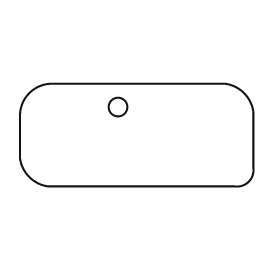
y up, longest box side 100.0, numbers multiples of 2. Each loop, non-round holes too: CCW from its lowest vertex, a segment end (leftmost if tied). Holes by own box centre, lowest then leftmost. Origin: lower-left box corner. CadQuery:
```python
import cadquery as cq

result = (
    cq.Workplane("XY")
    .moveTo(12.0, 0.0)
    .lineTo(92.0, 0.0)
    .threePointArc((98.0, 2.0), (100.0, 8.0))
    .lineTo(100.0, 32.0)
    .threePointArc((96.0, 40.0), (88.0, 44.0))
    .lineTo(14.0, 44.0)
    .threePointArc((4.0, 40.0), (0.0, 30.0))
    .lineTo(0.0, 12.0)
    .threePointArc((4.0, 4.0), (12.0, 0.0))
    .close()
    .moveTo(42.0, 34.0)
    .circle(4.0)
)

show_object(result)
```